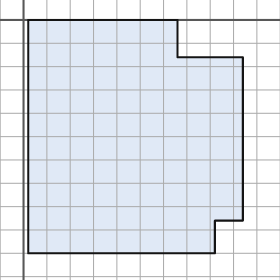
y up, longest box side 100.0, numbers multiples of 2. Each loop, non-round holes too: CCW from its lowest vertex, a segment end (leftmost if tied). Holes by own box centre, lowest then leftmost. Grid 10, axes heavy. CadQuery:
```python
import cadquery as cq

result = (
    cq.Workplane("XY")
    .moveTo(2.0, -100.0)
    .lineTo(82.0, -100.0)
    .lineTo(82.0, -86.0)
    .lineTo(94.0, -86.0)
    .lineTo(94.0, -16.0)
    .lineTo(66.0, -16.0)
    .lineTo(66.0, 0.0)
    .lineTo(2.0, 0.0)
    .close()
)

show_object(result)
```